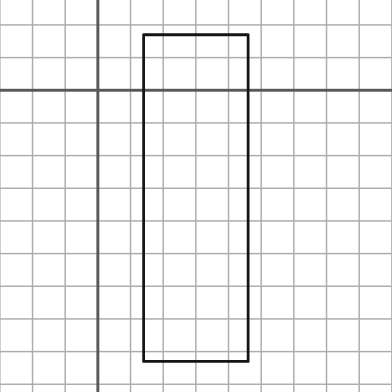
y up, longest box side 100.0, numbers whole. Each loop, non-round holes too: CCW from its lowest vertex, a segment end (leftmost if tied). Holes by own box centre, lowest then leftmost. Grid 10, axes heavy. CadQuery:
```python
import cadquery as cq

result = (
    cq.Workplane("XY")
    .moveTo(14.0, -83.0)
    .lineTo(46.0, -83.0)
    .lineTo(46.0, 17.0)
    .lineTo(14.0, 17.0)
    .close()
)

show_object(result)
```